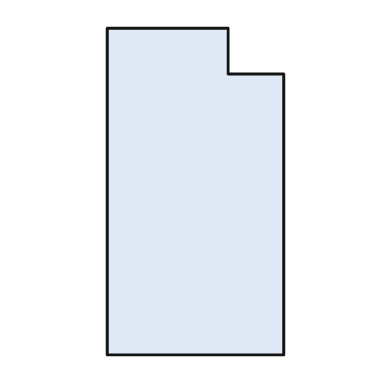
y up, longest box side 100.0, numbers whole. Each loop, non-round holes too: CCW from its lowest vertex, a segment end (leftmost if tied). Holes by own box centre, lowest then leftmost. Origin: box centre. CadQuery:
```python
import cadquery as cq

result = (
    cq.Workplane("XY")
    .moveTo(-27.0, -50.0)
    .lineTo(27.0, -50.0)
    .lineTo(27.0, 36.0)
    .lineTo(10.0, 36.0)
    .lineTo(10.0, 50.0)
    .lineTo(-27.0, 50.0)
    .close()
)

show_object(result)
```